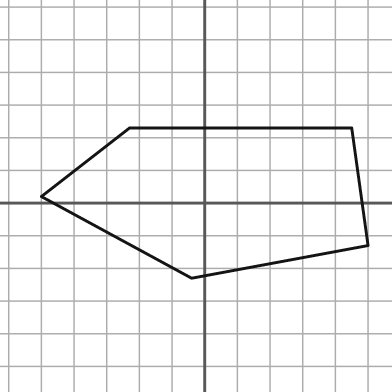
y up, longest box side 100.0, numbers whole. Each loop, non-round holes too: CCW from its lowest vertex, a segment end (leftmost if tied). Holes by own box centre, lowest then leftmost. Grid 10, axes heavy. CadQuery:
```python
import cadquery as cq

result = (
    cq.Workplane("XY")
    .moveTo(-4.0, -23.0)
    .lineTo(50.0, -13.0)
    .lineTo(45.0, 23.0)
    .lineTo(-23.0, 23.0)
    .lineTo(-50.0, 2.0)
    .close()
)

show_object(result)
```